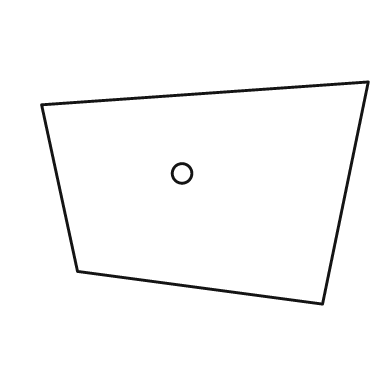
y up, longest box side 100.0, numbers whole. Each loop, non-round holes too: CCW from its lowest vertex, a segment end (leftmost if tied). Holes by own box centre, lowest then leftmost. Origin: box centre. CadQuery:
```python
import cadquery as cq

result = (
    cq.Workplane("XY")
    .moveTo(36.0, -34.0)
    .lineTo(50.0, 34.0)
    .lineTo(-50.0, 27.0)
    .lineTo(-39.0, -24.0)
    .close()
    .moveTo(-7.0, 6.0)
    .circle(3.0)
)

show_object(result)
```